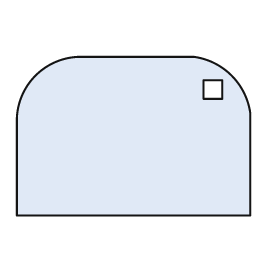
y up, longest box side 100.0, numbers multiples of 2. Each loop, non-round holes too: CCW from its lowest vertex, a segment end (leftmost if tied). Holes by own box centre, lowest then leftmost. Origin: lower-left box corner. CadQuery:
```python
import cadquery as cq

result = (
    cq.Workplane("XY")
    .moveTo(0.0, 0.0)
    .lineTo(100.0, 0.0)
    .lineTo(100.0, 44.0)
    .threePointArc((92.0, 60.0), (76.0, 68.0))
    .lineTo(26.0, 68.0)
    .threePointArc((8.0, 60.0), (0.0, 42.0))
    .close()
    .moveTo(80.0, 50.0)
    .lineTo(88.0, 50.0)
    .lineTo(88.0, 58.0)
    .lineTo(80.0, 58.0)
    .close()
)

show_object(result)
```